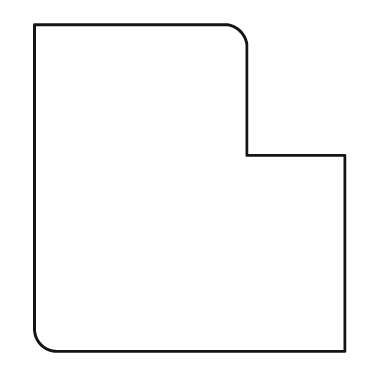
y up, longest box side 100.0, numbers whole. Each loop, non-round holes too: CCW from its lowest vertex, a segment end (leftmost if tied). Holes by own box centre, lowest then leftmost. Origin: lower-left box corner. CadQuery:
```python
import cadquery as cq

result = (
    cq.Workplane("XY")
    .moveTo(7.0, 0.0)
    .lineTo(95.0, 0.0)
    .lineTo(95.0, 60.0)
    .lineTo(65.0, 60.0)
    .lineTo(65.0, 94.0)
    .threePointArc((63.0, 98.0), (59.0, 100.0))
    .lineTo(0.0, 100.0)
    .lineTo(0.0, 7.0)
    .threePointArc((2.0, 2.0), (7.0, 0.0))
    .close()
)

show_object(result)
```